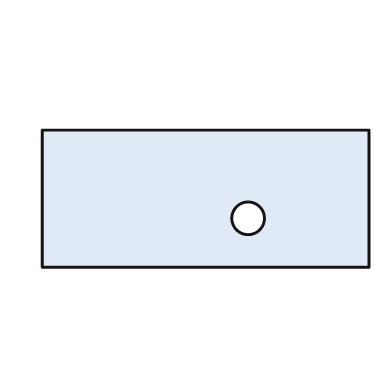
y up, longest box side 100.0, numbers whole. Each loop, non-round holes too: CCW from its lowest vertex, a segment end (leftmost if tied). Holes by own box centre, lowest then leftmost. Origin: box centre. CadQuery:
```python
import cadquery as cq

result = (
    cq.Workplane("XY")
    .moveTo(-50.0, -21.0)
    .lineTo(50.0, -21.0)
    .lineTo(50.0, 21.0)
    .lineTo(-50.0, 21.0)
    .close()
    .moveTo(13.0, -6.0)
    .circle(5.0)
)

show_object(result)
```